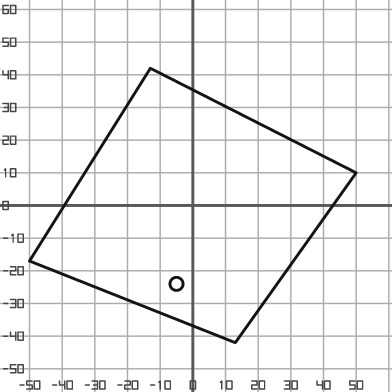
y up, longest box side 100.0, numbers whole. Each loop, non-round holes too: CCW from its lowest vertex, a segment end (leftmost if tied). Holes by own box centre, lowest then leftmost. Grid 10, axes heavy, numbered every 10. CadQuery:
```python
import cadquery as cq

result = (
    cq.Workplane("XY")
    .moveTo(13.0, -42.0)
    .lineTo(50.0, 10.0)
    .lineTo(-13.0, 42.0)
    .lineTo(-50.0, -17.0)
    .close()
    .moveTo(-5.0, -24.0)
    .circle(2.0)
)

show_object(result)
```